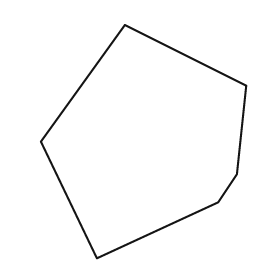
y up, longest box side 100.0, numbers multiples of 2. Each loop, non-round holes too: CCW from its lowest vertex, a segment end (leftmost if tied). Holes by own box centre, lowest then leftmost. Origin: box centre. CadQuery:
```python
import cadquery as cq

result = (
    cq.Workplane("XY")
    .moveTo(-20.0, -50.0)
    .lineTo(32.0, -26.0)
    .lineTo(40.0, -14.0)
    .lineTo(44.0, 24.0)
    .lineTo(-8.0, 50.0)
    .lineTo(-44.0, 0.0)
    .close()
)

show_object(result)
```